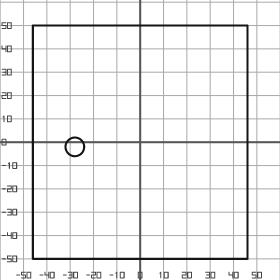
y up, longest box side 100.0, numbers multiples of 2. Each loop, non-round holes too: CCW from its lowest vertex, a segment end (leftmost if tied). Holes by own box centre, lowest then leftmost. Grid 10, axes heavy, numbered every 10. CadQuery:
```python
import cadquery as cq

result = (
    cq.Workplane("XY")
    .moveTo(-46.0, -50.0)
    .lineTo(46.0, -50.0)
    .lineTo(46.0, 50.0)
    .lineTo(-46.0, 50.0)
    .close()
    .moveTo(-28.0, -2.0)
    .circle(4.0)
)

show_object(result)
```